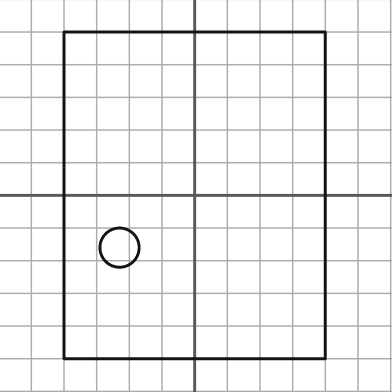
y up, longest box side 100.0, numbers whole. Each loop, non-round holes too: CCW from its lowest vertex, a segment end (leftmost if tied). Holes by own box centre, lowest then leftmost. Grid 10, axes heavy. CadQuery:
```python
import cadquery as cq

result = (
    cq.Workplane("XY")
    .moveTo(-40.0, -50.0)
    .lineTo(40.0, -50.0)
    .lineTo(40.0, 50.0)
    .lineTo(-40.0, 50.0)
    .close()
    .moveTo(-23.0, -16.0)
    .circle(6.0)
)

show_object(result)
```